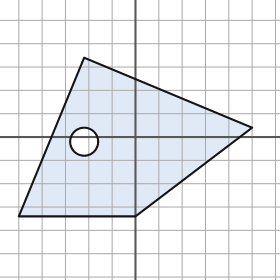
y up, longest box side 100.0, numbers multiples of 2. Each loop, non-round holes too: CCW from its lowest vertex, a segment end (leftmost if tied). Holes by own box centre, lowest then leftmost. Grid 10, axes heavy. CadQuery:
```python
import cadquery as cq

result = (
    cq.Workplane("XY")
    .moveTo(-50.0, -34.0)
    .lineTo(0.0, -34.0)
    .lineTo(50.0, 4.0)
    .lineTo(-22.0, 34.0)
    .close()
    .moveTo(-22.0, -2.0)
    .circle(6.0)
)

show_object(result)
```